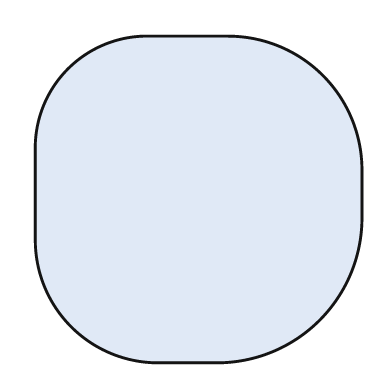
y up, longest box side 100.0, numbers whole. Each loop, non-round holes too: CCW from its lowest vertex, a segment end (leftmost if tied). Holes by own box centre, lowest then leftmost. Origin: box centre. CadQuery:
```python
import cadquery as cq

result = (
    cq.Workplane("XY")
    .moveTo(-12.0, -50.0)
    .lineTo(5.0, -50.0)
    .threePointArc((37.0, -37.0), (50.0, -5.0))
    .lineTo(50.0, 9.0)
    .threePointArc((38.0, 38.0), (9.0, 50.0))
    .lineTo(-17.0, 50.0)
    .threePointArc((-40.0, 40.0), (-50.0, 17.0))
    .lineTo(-50.0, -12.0)
    .threePointArc((-39.0, -39.0), (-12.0, -50.0))
    .close()
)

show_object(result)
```